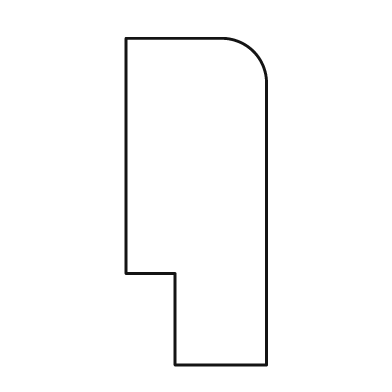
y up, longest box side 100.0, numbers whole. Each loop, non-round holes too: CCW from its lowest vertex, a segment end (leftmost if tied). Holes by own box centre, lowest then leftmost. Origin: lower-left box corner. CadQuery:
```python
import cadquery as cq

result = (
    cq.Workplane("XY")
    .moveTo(15.0, 0.0)
    .lineTo(43.0, 0.0)
    .lineTo(43.0, 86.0)
    .threePointArc((39.0, 96.0), (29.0, 100.0))
    .lineTo(0.0, 100.0)
    .lineTo(0.0, 28.0)
    .lineTo(15.0, 28.0)
    .close()
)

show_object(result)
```